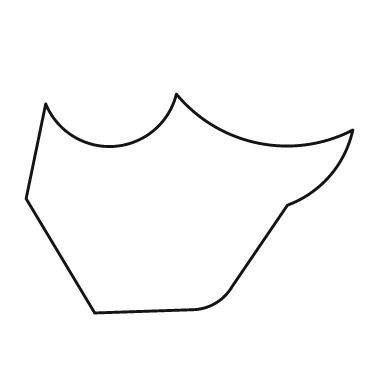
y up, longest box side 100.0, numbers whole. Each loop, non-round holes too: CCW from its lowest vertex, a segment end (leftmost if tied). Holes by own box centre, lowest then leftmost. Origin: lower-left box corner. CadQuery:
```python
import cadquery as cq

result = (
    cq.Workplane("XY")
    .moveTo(21.0, 0.0)
    .lineTo(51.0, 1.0)
    .threePointArc((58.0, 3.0), (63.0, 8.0))
    .lineTo(80.0, 33.0)
    .threePointArc((93.0, 42.0), (100.0, 56.0))
    .threePointArc((71.0, 52.0), (46.0, 67.0))
    .threePointArc((27.0, 51.0), (6.0, 64.0))
    .lineTo(0.0, 35.0)
    .close()
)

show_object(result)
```